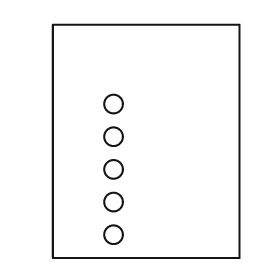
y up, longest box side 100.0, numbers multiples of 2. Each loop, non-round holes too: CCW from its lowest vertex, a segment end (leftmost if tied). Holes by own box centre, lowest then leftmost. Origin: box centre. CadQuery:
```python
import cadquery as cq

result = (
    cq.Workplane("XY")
    .moveTo(-40.0, -50.0)
    .lineTo(40.0, -50.0)
    .lineTo(40.0, 50.0)
    .lineTo(-40.0, 50.0)
    .close()
    .moveTo(-14.0, -40.0)
    .circle(4.0)
    .moveTo(-14.0, -26.0)
    .circle(4.0)
    .moveTo(-14.0, -12.0)
    .circle(4.0)
    .moveTo(-14.0, 2.0)
    .circle(4.0)
    .moveTo(-14.0, 16.0)
    .circle(4.0)
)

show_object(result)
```